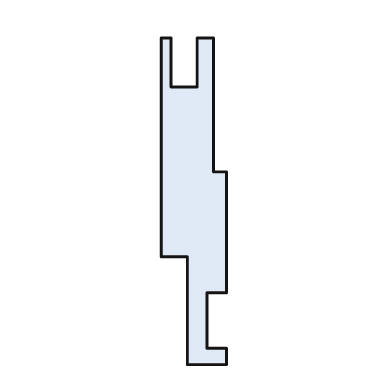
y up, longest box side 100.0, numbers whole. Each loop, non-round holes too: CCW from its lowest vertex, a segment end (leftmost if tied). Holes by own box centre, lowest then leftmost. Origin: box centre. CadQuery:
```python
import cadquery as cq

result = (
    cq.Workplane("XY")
    .moveTo(-2.0, -50.0)
    .lineTo(10.0, -50.0)
    .lineTo(10.0, -45.0)
    .lineTo(4.0, -45.0)
    .lineTo(4.0, -28.0)
    .lineTo(10.0, -28.0)
    .lineTo(10.0, 9.0)
    .lineTo(6.0, 9.0)
    .lineTo(6.0, 50.0)
    .lineTo(1.0, 50.0)
    .lineTo(1.0, 35.0)
    .lineTo(-7.0, 35.0)
    .lineTo(-7.0, 50.0)
    .lineTo(-10.0, 50.0)
    .lineTo(-10.0, -17.0)
    .lineTo(-2.0, -17.0)
    .close()
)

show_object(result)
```